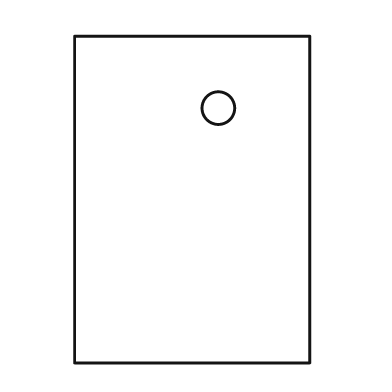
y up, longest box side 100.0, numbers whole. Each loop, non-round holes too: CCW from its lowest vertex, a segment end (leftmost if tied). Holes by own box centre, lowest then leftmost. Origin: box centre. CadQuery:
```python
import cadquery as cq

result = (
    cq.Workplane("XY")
    .moveTo(-36.0, -50.0)
    .lineTo(36.0, -50.0)
    .lineTo(36.0, 50.0)
    .lineTo(-36.0, 50.0)
    .close()
    .moveTo(8.0, 28.0)
    .circle(5.0)
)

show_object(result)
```